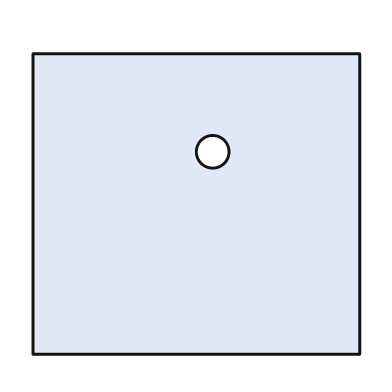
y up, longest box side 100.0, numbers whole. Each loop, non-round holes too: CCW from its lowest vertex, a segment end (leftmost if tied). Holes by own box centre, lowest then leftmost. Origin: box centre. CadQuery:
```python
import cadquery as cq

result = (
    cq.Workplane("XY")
    .moveTo(-50.0, -46.0)
    .lineTo(50.0, -46.0)
    .lineTo(50.0, 46.0)
    .lineTo(-50.0, 46.0)
    .close()
    .moveTo(5.0, 16.0)
    .circle(5.0)
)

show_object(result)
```